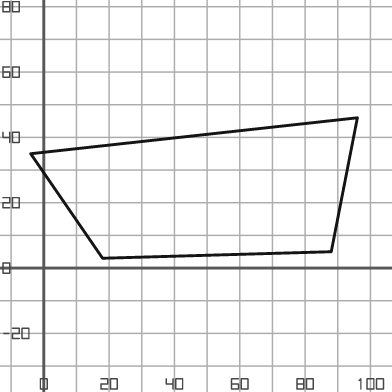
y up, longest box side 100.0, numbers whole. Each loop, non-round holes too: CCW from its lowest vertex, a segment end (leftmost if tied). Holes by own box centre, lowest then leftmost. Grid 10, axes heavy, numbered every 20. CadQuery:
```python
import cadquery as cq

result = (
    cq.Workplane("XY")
    .moveTo(18.0, 3.0)
    .lineTo(88.0, 5.0)
    .lineTo(96.0, 46.0)
    .lineTo(-4.0, 35.0)
    .close()
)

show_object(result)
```